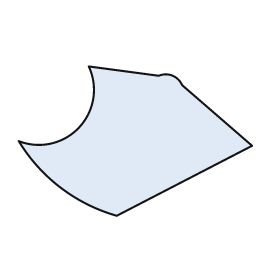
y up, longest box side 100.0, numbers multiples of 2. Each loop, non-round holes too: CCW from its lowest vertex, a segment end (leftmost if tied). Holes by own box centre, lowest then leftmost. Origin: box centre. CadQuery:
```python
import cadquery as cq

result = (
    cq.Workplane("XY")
    .moveTo(-8.0, -32.0)
    .lineTo(50.0, -2.0)
    .lineTo(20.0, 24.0)
    .threePointArc((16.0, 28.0), (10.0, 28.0))
    .lineTo(-20.0, 32.0)
    .threePointArc((-24.0, 6.0), (-50.0, 0.0))
    .threePointArc((-32.0, -20.0), (-8.0, -32.0))
    .close()
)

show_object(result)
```